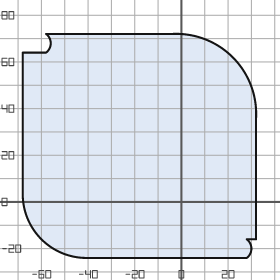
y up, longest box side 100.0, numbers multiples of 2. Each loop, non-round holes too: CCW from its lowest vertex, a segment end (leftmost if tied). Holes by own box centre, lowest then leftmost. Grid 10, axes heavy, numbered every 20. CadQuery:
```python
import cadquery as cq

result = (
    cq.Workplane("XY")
    .moveTo(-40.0, -24.0)
    .lineTo(28.0, -24.0)
    .threePointArc((30.0, -20.0), (28.0, -16.0))
    .lineTo(32.0, -16.0)
    .lineTo(32.0, 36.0)
    .threePointArc((22.0, 62.0), (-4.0, 72.0))
    .lineTo(-58.0, 72.0)
    .threePointArc((-56.0, 68.0), (-58.0, 64.0))
    .lineTo(-68.0, 64.0)
    .lineTo(-68.0, 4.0)
    .threePointArc((-60.0, -16.0), (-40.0, -24.0))
    .close()
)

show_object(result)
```